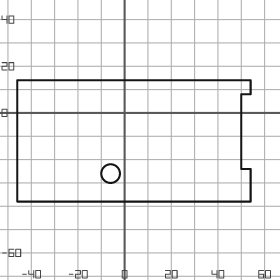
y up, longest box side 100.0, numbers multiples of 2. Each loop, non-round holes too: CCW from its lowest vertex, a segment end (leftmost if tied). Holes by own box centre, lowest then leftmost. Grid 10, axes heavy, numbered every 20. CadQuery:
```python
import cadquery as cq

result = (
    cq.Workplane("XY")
    .moveTo(-46.0, -38.0)
    .lineTo(54.0, -38.0)
    .lineTo(54.0, -24.0)
    .lineTo(50.0, -24.0)
    .lineTo(50.0, 8.0)
    .lineTo(54.0, 8.0)
    .lineTo(54.0, 14.0)
    .lineTo(-46.0, 14.0)
    .close()
    .moveTo(-6.0, -26.0)
    .circle(4.0)
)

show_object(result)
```